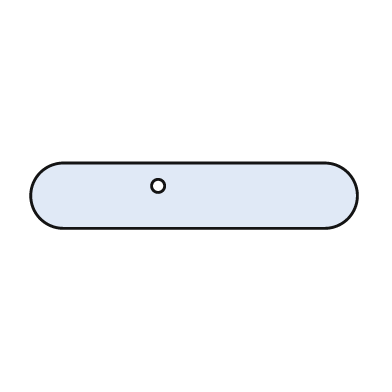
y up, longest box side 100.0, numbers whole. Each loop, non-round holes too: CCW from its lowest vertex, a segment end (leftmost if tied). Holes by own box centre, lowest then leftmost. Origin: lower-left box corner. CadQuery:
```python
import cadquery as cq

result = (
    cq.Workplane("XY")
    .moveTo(10.0, 0.0)
    .lineTo(90.0, 0.0)
    .threePointArc((100.0, 10.0), (90.0, 20.0))
    .lineTo(10.0, 20.0)
    .threePointArc((0.0, 10.0), (10.0, 0.0))
    .close()
    .moveTo(39.0, 13.0)
    .circle(2.0)
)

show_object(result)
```